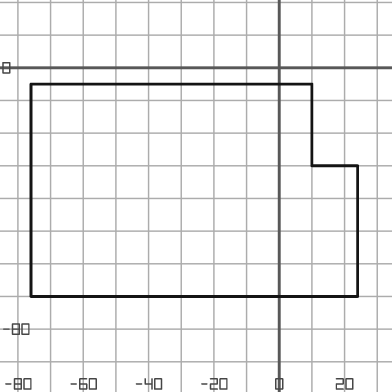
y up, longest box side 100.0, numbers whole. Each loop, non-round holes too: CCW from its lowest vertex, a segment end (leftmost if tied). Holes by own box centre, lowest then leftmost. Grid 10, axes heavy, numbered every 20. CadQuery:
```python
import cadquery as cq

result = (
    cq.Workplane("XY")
    .moveTo(-76.0, -70.0)
    .lineTo(24.0, -70.0)
    .lineTo(24.0, -30.0)
    .lineTo(10.0, -30.0)
    .lineTo(10.0, -5.0)
    .lineTo(-76.0, -5.0)
    .close()
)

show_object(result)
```